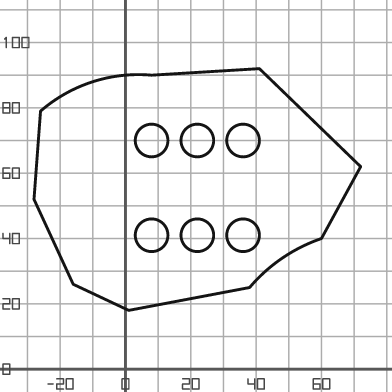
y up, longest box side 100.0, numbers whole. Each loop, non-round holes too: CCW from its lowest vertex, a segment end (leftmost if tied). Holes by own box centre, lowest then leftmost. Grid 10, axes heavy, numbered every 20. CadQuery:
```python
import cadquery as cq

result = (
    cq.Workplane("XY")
    .moveTo(1.0, 18.0)
    .lineTo(38.0, 25.0)
    .threePointArc((48.0, 34.0), (60.0, 40.0))
    .lineTo(72.0, 62.0)
    .lineTo(41.0, 92.0)
    .lineTo(8.0, 90.0)
    .threePointArc((-10.0, 88.0), (-26.0, 79.0))
    .lineTo(-28.0, 52.0)
    .lineTo(-16.0, 26.0)
    .close()
    .moveTo(8.0, 41.0)
    .circle(5.0)
    .moveTo(22.0, 41.0)
    .circle(5.0)
    .moveTo(36.0, 41.0)
    .circle(5.0)
    .moveTo(8.0, 70.0)
    .circle(5.0)
    .moveTo(22.0, 70.0)
    .circle(5.0)
    .moveTo(36.0, 70.0)
    .circle(5.0)
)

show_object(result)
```